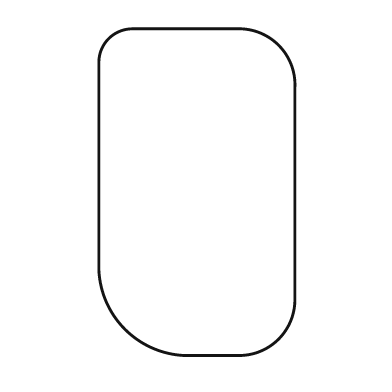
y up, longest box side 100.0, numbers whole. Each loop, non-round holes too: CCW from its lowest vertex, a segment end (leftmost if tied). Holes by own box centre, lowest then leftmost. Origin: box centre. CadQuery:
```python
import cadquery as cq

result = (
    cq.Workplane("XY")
    .moveTo(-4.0, -50.0)
    .lineTo(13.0, -50.0)
    .threePointArc((25.0, -45.0), (30.0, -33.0))
    .lineTo(30.0, 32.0)
    .threePointArc((25.0, 45.0), (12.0, 50.0))
    .lineTo(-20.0, 50.0)
    .threePointArc((-27.0, 47.0), (-30.0, 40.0))
    .lineTo(-30.0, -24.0)
    .threePointArc((-22.0, -42.0), (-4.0, -50.0))
    .close()
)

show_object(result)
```